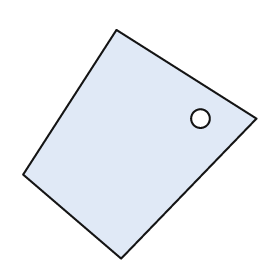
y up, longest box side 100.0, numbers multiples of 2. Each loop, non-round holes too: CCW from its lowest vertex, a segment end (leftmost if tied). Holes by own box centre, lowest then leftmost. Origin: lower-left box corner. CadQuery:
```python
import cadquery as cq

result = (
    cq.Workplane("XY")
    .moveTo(42.0, 0.0)
    .lineTo(100.0, 60.0)
    .lineTo(40.0, 98.0)
    .lineTo(0.0, 36.0)
    .close()
    .moveTo(76.0, 60.0)
    .circle(4.0)
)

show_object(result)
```